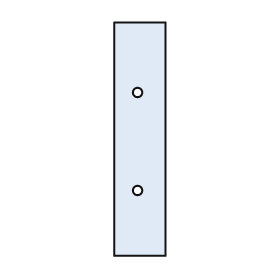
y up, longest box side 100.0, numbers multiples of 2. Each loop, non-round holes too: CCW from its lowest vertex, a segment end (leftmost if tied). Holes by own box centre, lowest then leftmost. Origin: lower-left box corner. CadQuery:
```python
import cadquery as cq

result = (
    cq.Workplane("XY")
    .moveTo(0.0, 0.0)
    .lineTo(22.0, 0.0)
    .lineTo(22.0, 100.0)
    .lineTo(0.0, 100.0)
    .close()
    .moveTo(10.0, 28.0)
    .circle(2.0)
    .moveTo(10.0, 70.0)
    .circle(2.0)
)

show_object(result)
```